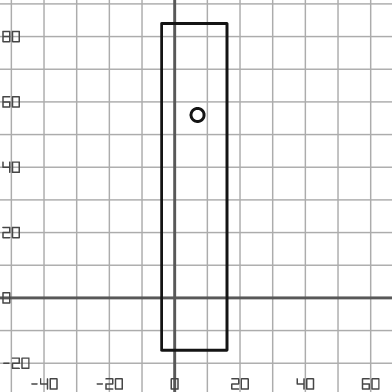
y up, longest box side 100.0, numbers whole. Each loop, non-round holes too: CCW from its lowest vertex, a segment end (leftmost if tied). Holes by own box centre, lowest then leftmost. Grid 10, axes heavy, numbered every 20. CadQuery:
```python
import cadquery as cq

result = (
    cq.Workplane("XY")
    .moveTo(-4.0, -16.0)
    .lineTo(16.0, -16.0)
    .lineTo(16.0, 84.0)
    .lineTo(-4.0, 84.0)
    .close()
    .moveTo(7.0, 56.0)
    .circle(2.0)
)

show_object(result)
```